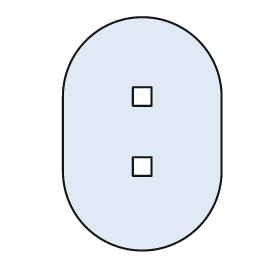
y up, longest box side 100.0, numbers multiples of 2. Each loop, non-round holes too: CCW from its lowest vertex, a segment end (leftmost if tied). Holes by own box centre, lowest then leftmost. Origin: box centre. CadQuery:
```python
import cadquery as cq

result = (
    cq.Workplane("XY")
    .moveTo(-34.0, -16.0)
    .threePointArc((0.0, -50.0), (34.0, -16.0))
    .lineTo(34.0, 16.0)
    .threePointArc((0.0, 50.0), (-34.0, 16.0))
    .close()
    .moveTo(-4.0, -18.0)
    .lineTo(4.0, -18.0)
    .lineTo(4.0, -10.0)
    .lineTo(-4.0, -10.0)
    .close()
    .moveTo(-4.0, 12.0)
    .lineTo(4.0, 12.0)
    .lineTo(4.0, 20.0)
    .lineTo(-4.0, 20.0)
    .close()
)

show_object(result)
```